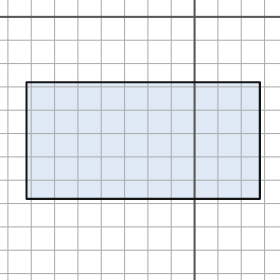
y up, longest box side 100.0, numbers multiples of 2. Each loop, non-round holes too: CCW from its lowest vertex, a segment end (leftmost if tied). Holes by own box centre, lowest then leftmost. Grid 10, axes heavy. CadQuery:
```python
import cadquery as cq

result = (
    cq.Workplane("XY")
    .moveTo(-72.0, -78.0)
    .lineTo(28.0, -78.0)
    .lineTo(28.0, -28.0)
    .lineTo(-72.0, -28.0)
    .close()
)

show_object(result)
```